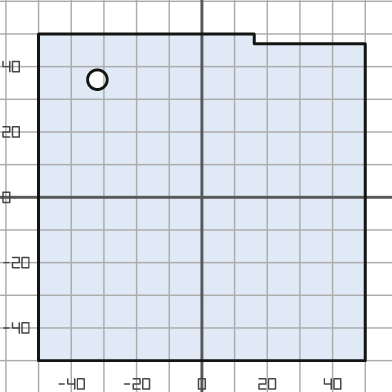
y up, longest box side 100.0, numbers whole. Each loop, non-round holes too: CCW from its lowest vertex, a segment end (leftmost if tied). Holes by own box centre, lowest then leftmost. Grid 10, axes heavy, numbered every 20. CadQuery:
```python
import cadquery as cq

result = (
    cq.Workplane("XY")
    .moveTo(-50.0, -50.0)
    .lineTo(50.0, -50.0)
    .lineTo(50.0, 47.0)
    .lineTo(16.0, 47.0)
    .lineTo(16.0, 50.0)
    .lineTo(-50.0, 50.0)
    .close()
    .moveTo(-32.0, 36.0)
    .circle(3.0)
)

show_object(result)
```